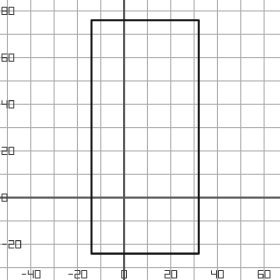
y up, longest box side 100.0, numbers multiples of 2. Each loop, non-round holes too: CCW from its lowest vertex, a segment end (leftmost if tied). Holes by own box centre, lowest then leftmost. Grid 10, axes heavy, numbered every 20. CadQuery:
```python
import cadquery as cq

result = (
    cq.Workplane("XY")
    .moveTo(-14.0, -24.0)
    .lineTo(32.0, -24.0)
    .lineTo(32.0, 76.0)
    .lineTo(-14.0, 76.0)
    .close()
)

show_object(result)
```